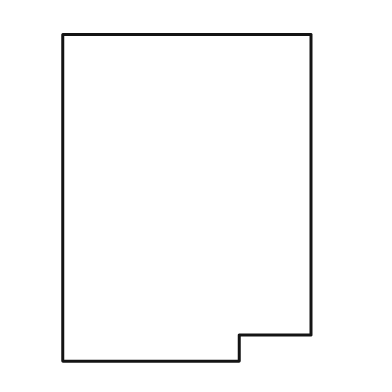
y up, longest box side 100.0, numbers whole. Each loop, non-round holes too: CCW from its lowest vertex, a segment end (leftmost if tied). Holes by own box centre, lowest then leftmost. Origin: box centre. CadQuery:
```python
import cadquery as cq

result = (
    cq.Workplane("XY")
    .moveTo(-38.0, -50.0)
    .lineTo(16.0, -50.0)
    .lineTo(16.0, -42.0)
    .lineTo(38.0, -42.0)
    .lineTo(38.0, 50.0)
    .lineTo(-38.0, 50.0)
    .close()
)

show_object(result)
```